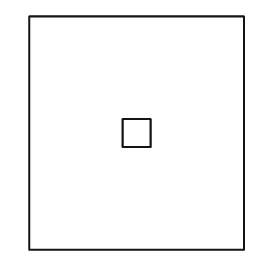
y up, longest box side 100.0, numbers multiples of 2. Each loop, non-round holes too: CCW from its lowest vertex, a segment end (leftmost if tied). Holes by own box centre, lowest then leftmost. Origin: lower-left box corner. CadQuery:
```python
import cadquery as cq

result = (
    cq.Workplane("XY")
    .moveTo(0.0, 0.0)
    .lineTo(92.0, 0.0)
    .lineTo(92.0, 100.0)
    .lineTo(0.0, 100.0)
    .close()
    .moveTo(40.0, 44.0)
    .lineTo(52.0, 44.0)
    .lineTo(52.0, 56.0)
    .lineTo(40.0, 56.0)
    .close()
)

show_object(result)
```